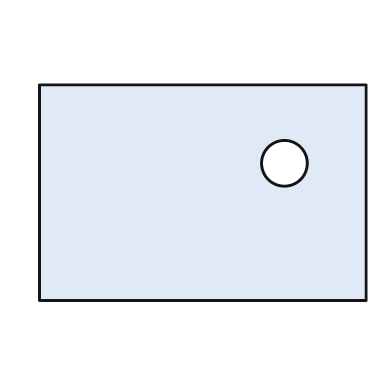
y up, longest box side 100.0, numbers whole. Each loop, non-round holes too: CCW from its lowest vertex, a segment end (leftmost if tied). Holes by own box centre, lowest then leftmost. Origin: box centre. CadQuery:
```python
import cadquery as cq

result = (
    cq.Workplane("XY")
    .moveTo(-50.0, -33.0)
    .lineTo(50.0, -33.0)
    .lineTo(50.0, 33.0)
    .lineTo(-50.0, 33.0)
    .close()
    .moveTo(25.0, 9.0)
    .circle(7.0)
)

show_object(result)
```